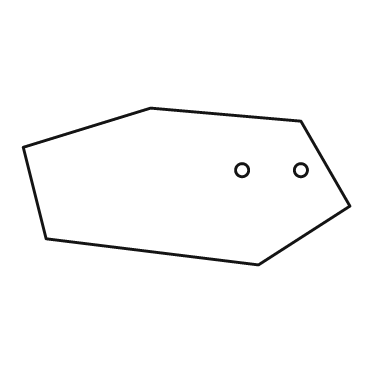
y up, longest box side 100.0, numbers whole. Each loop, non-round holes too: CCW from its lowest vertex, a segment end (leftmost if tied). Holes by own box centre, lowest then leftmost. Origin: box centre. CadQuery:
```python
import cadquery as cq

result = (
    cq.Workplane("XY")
    .moveTo(22.0, -24.0)
    .lineTo(50.0, -6.0)
    .lineTo(35.0, 20.0)
    .lineTo(-11.0, 24.0)
    .lineTo(-50.0, 12.0)
    .lineTo(-43.0, -16.0)
    .close()
    .moveTo(17.0, 5.0)
    .circle(2.0)
    .moveTo(35.0, 5.0)
    .circle(2.0)
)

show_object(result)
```